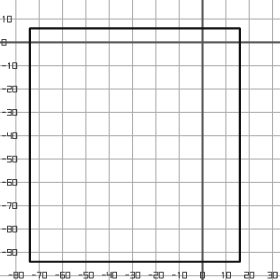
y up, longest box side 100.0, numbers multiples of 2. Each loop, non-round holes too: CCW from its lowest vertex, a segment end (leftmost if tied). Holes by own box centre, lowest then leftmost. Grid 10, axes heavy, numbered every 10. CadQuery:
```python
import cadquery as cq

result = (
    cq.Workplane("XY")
    .moveTo(-74.0, -94.0)
    .lineTo(16.0, -94.0)
    .lineTo(16.0, 6.0)
    .lineTo(-74.0, 6.0)
    .close()
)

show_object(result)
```